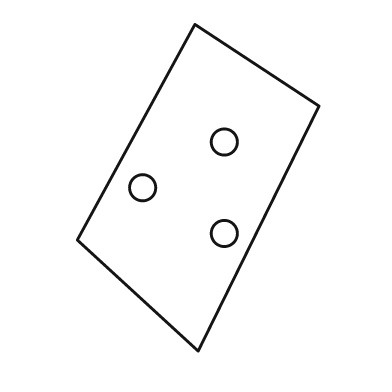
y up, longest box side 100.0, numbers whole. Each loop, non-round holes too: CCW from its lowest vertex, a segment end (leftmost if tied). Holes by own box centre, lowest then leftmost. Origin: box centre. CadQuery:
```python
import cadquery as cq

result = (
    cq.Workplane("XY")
    .moveTo(0.0, -50.0)
    .lineTo(37.0, 25.0)
    .lineTo(-1.0, 50.0)
    .lineTo(-37.0, -16.0)
    .close()
    .moveTo(8.0, -14.0)
    .circle(4.0)
    .moveTo(-17.0, 0.0)
    .circle(4.0)
    .moveTo(8.0, 14.0)
    .circle(4.0)
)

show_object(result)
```